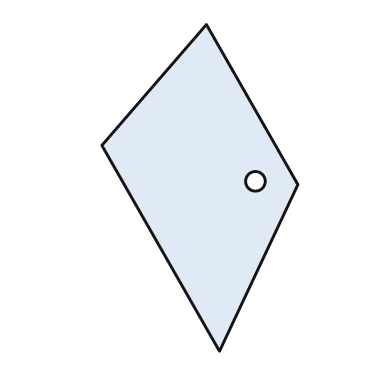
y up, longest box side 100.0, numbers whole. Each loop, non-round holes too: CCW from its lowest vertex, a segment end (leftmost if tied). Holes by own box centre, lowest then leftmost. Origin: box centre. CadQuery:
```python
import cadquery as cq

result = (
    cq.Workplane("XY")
    .moveTo(6.0, -50.0)
    .lineTo(30.0, 1.0)
    .lineTo(2.0, 50.0)
    .lineTo(-30.0, 13.0)
    .close()
    .moveTo(17.0, 2.0)
    .circle(3.0)
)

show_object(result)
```